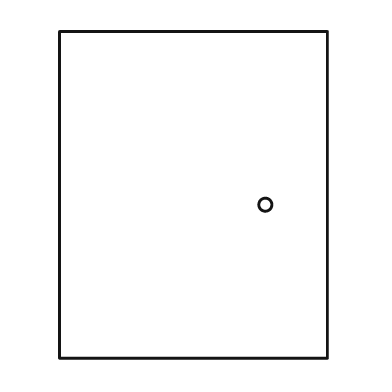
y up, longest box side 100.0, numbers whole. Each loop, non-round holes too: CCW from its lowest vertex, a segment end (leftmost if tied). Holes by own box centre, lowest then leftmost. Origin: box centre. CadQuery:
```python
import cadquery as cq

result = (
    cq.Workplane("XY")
    .moveTo(-41.0, -50.0)
    .lineTo(41.0, -50.0)
    .lineTo(41.0, 50.0)
    .lineTo(-41.0, 50.0)
    .close()
    .moveTo(22.0, -3.0)
    .circle(2.0)
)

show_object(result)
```